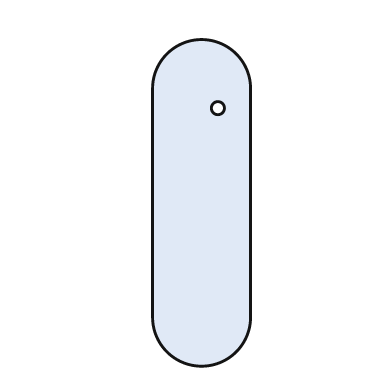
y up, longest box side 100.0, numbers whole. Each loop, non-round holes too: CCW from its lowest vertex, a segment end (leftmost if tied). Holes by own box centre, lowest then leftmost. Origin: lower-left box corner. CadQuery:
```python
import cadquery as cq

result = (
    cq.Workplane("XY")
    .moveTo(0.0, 15.0)
    .threePointArc((15.0, 0.0), (30.0, 15.0))
    .lineTo(30.0, 85.0)
    .threePointArc((15.0, 100.0), (0.0, 85.0))
    .close()
    .moveTo(20.0, 79.0)
    .circle(2.0)
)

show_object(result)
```